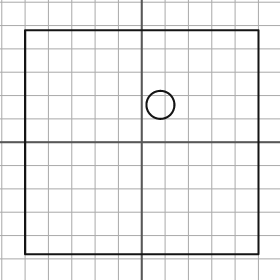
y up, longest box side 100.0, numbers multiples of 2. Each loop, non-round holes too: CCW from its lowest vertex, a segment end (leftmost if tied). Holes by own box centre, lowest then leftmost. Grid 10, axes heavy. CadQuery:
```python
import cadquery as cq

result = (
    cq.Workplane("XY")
    .moveTo(-50.0, -48.0)
    .lineTo(50.0, -48.0)
    .lineTo(50.0, 48.0)
    .lineTo(-50.0, 48.0)
    .close()
    .moveTo(8.0, 16.0)
    .circle(6.0)
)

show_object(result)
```